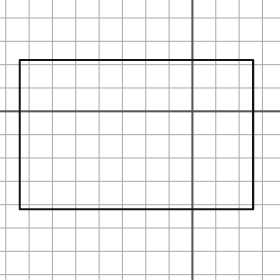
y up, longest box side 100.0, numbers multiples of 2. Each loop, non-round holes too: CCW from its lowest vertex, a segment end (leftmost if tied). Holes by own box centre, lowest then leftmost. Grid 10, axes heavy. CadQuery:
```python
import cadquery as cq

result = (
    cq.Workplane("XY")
    .moveTo(-74.0, -42.0)
    .lineTo(26.0, -42.0)
    .lineTo(26.0, 22.0)
    .lineTo(-74.0, 22.0)
    .close()
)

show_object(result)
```